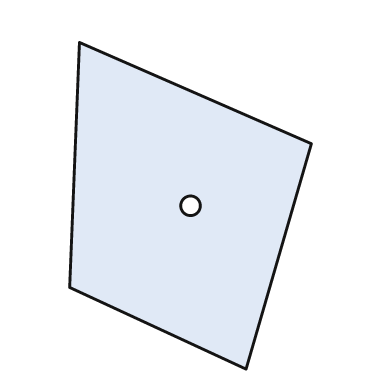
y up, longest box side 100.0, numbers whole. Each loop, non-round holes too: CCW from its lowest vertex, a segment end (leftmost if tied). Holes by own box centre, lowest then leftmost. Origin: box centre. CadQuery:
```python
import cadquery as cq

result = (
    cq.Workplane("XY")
    .moveTo(17.0, -50.0)
    .lineTo(37.0, 19.0)
    .lineTo(-34.0, 50.0)
    .lineTo(-37.0, -25.0)
    .close()
    .moveTo(0.0, 0.0)
    .circle(3.0)
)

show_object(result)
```